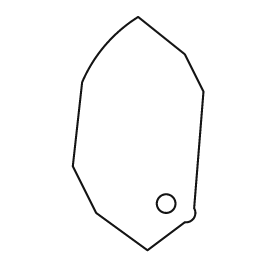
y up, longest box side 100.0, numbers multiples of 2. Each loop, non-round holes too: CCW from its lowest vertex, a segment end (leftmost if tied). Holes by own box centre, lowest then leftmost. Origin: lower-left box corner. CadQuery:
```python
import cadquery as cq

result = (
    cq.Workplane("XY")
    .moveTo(32.0, 0.0)
    .lineTo(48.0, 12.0)
    .threePointArc((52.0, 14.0), (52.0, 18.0))
    .lineTo(56.0, 68.0)
    .lineTo(48.0, 84.0)
    .lineTo(28.0, 100.0)
    .threePointArc((14.0, 88.0), (4.0, 72.0))
    .lineTo(0.0, 36.0)
    .lineTo(10.0, 16.0)
    .close()
    .moveTo(40.0, 20.0)
    .circle(4.0)
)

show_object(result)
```